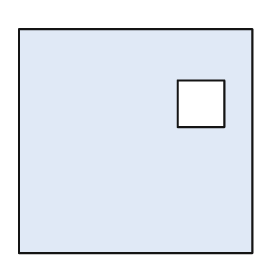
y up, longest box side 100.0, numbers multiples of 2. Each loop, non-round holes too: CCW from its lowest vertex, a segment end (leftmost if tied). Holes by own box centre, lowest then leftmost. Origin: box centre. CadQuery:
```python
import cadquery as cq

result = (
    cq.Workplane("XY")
    .moveTo(-50.0, -48.0)
    .lineTo(50.0, -48.0)
    .lineTo(50.0, 48.0)
    .lineTo(-50.0, 48.0)
    .close()
    .moveTo(18.0, 6.0)
    .lineTo(38.0, 6.0)
    .lineTo(38.0, 26.0)
    .lineTo(18.0, 26.0)
    .close()
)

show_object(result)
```